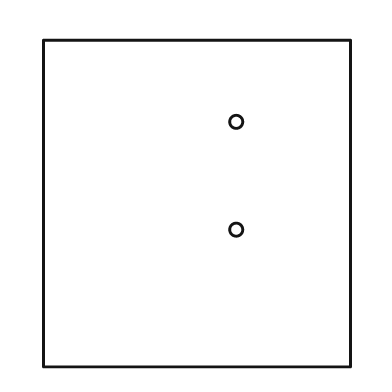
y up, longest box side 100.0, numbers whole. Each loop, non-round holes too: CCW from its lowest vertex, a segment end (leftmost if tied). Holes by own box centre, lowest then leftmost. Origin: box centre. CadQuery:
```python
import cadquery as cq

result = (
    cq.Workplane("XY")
    .moveTo(-47.0, -50.0)
    .lineTo(47.0, -50.0)
    .lineTo(47.0, 50.0)
    .lineTo(-47.0, 50.0)
    .close()
    .moveTo(12.0, -8.0)
    .circle(2.0)
    .moveTo(12.0, 25.0)
    .circle(2.0)
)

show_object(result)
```